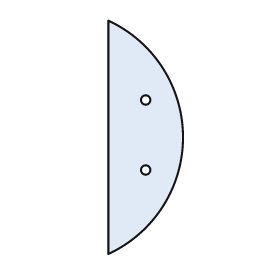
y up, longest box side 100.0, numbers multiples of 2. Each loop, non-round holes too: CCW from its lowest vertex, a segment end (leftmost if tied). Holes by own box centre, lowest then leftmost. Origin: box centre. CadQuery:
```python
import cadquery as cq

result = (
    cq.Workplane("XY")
    .moveTo(-16.0, -50.0)
    .threePointArc((16.0, 0.0), (-16.0, 50.0))
    .close()
    .moveTo(0.0, -14.0)
    .circle(2.0)
    .moveTo(0.0, 16.0)
    .circle(2.0)
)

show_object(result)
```